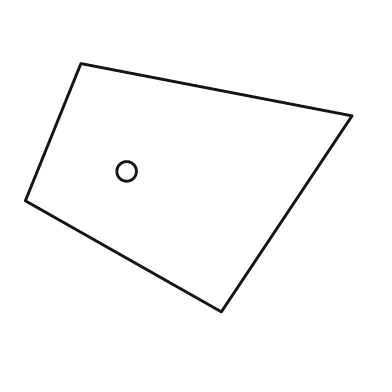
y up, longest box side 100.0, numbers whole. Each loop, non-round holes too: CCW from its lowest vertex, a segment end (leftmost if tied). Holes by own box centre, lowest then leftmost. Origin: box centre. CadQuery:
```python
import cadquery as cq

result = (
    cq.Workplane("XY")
    .moveTo(10.0, -38.0)
    .lineTo(50.0, 22.0)
    .lineTo(-33.0, 38.0)
    .lineTo(-50.0, -4.0)
    .close()
    .moveTo(-19.0, 5.0)
    .circle(3.0)
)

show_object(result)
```